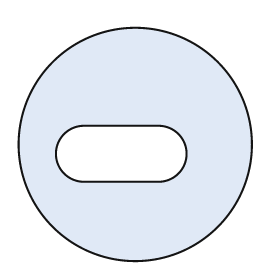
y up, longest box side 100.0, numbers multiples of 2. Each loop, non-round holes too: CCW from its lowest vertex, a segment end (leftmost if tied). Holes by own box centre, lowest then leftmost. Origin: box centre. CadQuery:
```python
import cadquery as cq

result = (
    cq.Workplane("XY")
    .moveTo(0.0, 0.0)
    .circle(50.0)
    .moveTo(-22.0, -16.0)
    .lineTo(10.0, -16.0)
    .threePointArc((22.0, -4.0), (10.0, 8.0))
    .lineTo(-22.0, 8.0)
    .threePointArc((-34.0, -4.0), (-22.0, -16.0))
    .close()
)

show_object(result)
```